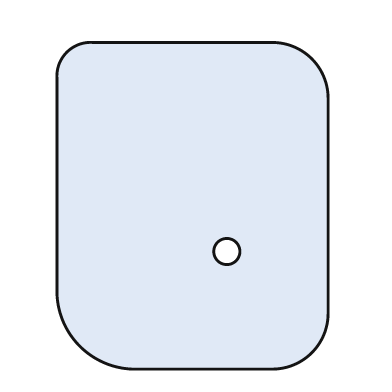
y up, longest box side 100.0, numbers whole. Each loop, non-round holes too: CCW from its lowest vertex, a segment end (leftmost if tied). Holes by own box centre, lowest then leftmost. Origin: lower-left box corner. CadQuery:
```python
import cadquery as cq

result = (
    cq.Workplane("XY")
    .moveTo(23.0, 0.0)
    .lineTo(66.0, 0.0)
    .threePointArc((78.0, 5.0), (83.0, 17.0))
    .lineTo(83.0, 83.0)
    .threePointArc((78.0, 95.0), (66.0, 100.0))
    .lineTo(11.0, 100.0)
    .threePointArc((3.0, 97.0), (0.0, 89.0))
    .lineTo(0.0, 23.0)
    .threePointArc((7.0, 7.0), (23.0, 0.0))
    .close()
    .moveTo(52.0, 36.0)
    .circle(4.0)
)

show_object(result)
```